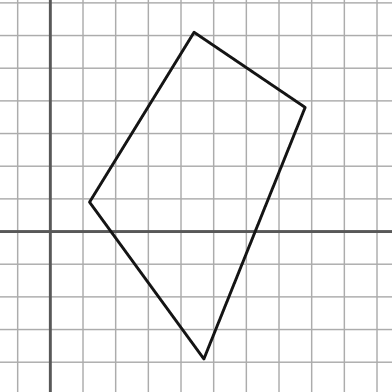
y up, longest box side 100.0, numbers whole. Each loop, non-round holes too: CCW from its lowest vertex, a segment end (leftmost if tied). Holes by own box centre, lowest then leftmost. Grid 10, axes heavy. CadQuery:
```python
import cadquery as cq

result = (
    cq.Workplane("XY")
    .moveTo(47.0, -39.0)
    .lineTo(78.0, 38.0)
    .lineTo(44.0, 61.0)
    .lineTo(12.0, 9.0)
    .close()
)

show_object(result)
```